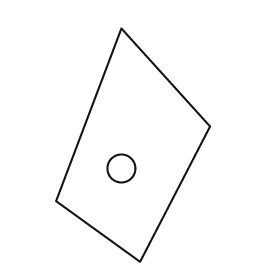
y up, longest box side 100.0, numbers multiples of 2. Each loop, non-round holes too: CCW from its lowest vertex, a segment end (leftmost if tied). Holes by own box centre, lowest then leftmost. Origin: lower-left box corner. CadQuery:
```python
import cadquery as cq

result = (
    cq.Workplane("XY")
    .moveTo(36.0, 0.0)
    .lineTo(66.0, 58.0)
    .lineTo(28.0, 100.0)
    .lineTo(0.0, 26.0)
    .close()
    .moveTo(28.0, 40.0)
    .circle(6.0)
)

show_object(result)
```